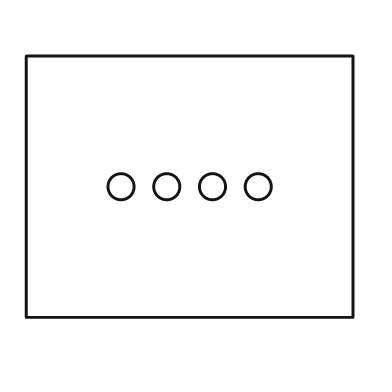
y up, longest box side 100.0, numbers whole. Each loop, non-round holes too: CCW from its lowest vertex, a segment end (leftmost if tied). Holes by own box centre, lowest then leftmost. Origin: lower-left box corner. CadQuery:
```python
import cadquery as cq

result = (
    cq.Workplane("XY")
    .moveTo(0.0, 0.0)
    .lineTo(100.0, 0.0)
    .lineTo(100.0, 80.0)
    .lineTo(0.0, 80.0)
    .close()
    .moveTo(29.0, 40.0)
    .circle(4.0)
    .moveTo(43.0, 40.0)
    .circle(4.0)
    .moveTo(57.0, 40.0)
    .circle(4.0)
    .moveTo(71.0, 40.0)
    .circle(4.0)
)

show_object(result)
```